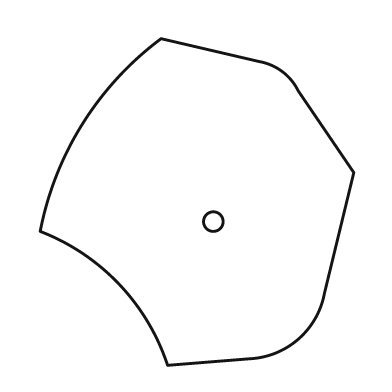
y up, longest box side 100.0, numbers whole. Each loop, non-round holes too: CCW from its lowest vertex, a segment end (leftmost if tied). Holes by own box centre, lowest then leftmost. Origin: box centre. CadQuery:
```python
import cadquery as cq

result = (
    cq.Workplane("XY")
    .moveTo(-9.0, -50.0)
    .lineTo(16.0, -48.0)
    .threePointArc((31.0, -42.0), (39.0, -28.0))
    .lineTo(48.0, 9.0)
    .lineTo(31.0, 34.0)
    .threePointArc((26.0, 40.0), (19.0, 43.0))
    .lineTo(-11.0, 50.0)
    .threePointArc((-35.0, 24.0), (-48.0, -9.0))
    .threePointArc((-24.0, -25.0), (-9.0, -50.0))
    .close()
    .moveTo(5.0, -6.0)
    .circle(3.0)
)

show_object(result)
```